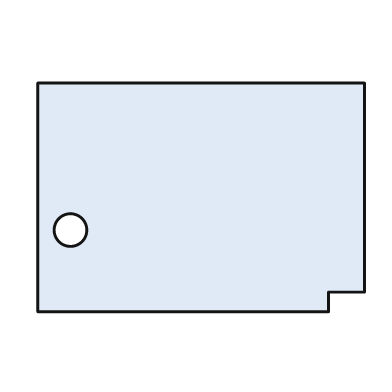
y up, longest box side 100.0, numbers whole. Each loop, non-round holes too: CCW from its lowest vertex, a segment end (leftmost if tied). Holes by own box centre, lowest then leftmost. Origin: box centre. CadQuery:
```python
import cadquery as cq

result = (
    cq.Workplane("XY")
    .moveTo(-50.0, -35.0)
    .lineTo(39.0, -35.0)
    .lineTo(39.0, -29.0)
    .lineTo(50.0, -29.0)
    .lineTo(50.0, 35.0)
    .lineTo(-50.0, 35.0)
    .close()
    .moveTo(-40.0, -10.0)
    .circle(5.0)
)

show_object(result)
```